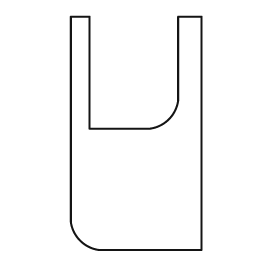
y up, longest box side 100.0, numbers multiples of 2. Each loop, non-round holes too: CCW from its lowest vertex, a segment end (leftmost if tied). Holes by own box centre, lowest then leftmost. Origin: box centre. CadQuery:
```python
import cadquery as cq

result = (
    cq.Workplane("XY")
    .moveTo(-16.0, -50.0)
    .lineTo(28.0, -50.0)
    .lineTo(28.0, 50.0)
    .lineTo(18.0, 50.0)
    .lineTo(18.0, 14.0)
    .threePointArc((14.0, 6.0), (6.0, 2.0))
    .lineTo(-20.0, 2.0)
    .lineTo(-20.0, 50.0)
    .lineTo(-28.0, 50.0)
    .lineTo(-28.0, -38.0)
    .threePointArc((-24.0, -46.0), (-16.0, -50.0))
    .close()
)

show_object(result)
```